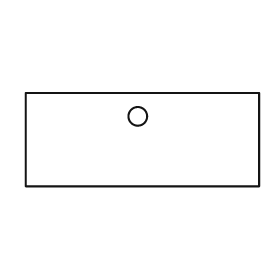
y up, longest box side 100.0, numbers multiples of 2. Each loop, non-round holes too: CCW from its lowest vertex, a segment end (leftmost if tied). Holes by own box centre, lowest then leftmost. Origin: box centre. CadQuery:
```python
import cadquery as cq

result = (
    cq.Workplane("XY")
    .moveTo(-50.0, -20.0)
    .lineTo(50.0, -20.0)
    .lineTo(50.0, 20.0)
    .lineTo(-50.0, 20.0)
    .close()
    .moveTo(-2.0, 10.0)
    .circle(4.0)
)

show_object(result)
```